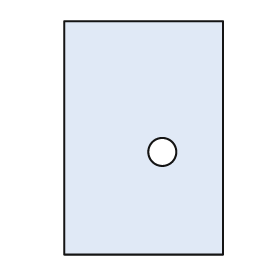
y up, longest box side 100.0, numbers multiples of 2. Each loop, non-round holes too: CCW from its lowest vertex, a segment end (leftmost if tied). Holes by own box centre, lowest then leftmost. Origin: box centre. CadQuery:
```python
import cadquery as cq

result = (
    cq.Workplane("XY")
    .moveTo(-34.0, -50.0)
    .lineTo(34.0, -50.0)
    .lineTo(34.0, 50.0)
    .lineTo(-34.0, 50.0)
    .close()
    .moveTo(8.0, -6.0)
    .circle(6.0)
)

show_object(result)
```